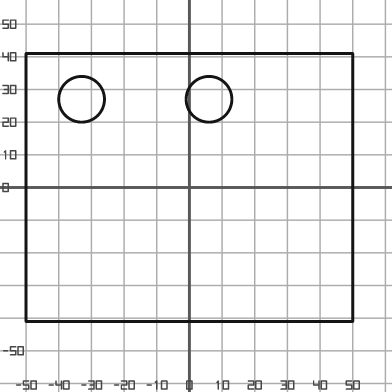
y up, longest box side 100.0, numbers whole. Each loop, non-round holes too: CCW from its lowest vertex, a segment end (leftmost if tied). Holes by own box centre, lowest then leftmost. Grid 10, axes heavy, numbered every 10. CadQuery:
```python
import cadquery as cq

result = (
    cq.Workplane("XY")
    .moveTo(-50.0, -41.0)
    .lineTo(50.0, -41.0)
    .lineTo(50.0, 41.0)
    .lineTo(-50.0, 41.0)
    .close()
    .moveTo(-33.0, 27.0)
    .circle(7.0)
    .moveTo(6.0, 27.0)
    .circle(7.0)
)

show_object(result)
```